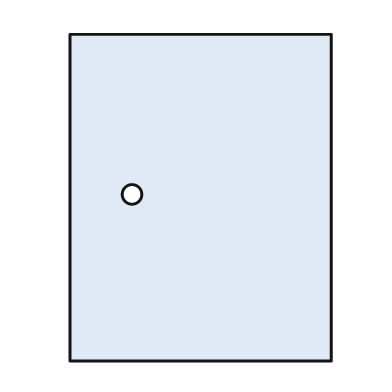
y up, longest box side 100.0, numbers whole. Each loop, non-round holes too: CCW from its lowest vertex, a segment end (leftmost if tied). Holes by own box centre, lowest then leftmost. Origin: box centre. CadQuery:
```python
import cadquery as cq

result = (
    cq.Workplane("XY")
    .moveTo(-40.0, -50.0)
    .lineTo(40.0, -50.0)
    .lineTo(40.0, 50.0)
    .lineTo(-40.0, 50.0)
    .close()
    .moveTo(-21.0, 1.0)
    .circle(3.0)
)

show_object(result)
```